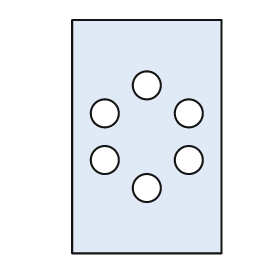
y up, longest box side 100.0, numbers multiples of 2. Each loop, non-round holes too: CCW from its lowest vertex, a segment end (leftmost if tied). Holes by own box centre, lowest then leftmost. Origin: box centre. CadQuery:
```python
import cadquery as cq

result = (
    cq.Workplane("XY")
    .moveTo(-32.0, -50.0)
    .lineTo(32.0, -50.0)
    .lineTo(32.0, 50.0)
    .lineTo(-32.0, 50.0)
    .close()
    .moveTo(0.0, -22.0)
    .circle(6.0)
    .moveTo(-18.0, -10.0)
    .circle(6.0)
    .moveTo(18.0, -10.0)
    .circle(6.0)
    .moveTo(-18.0, 10.0)
    .circle(6.0)
    .moveTo(18.0, 10.0)
    .circle(6.0)
    .moveTo(0.0, 22.0)
    .circle(6.0)
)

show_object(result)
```